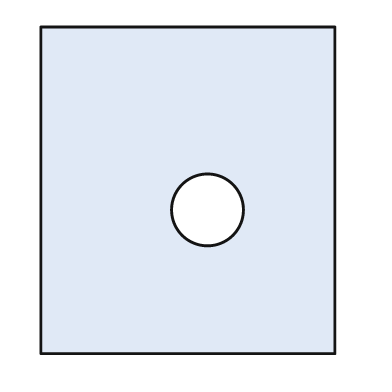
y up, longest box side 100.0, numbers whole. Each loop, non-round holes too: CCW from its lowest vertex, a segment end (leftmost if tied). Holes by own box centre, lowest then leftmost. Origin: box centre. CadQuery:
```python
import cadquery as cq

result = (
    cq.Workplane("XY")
    .moveTo(-45.0, -50.0)
    .lineTo(45.0, -50.0)
    .lineTo(45.0, 50.0)
    .lineTo(-45.0, 50.0)
    .close()
    .moveTo(6.0, -6.0)
    .circle(11.0)
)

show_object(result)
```